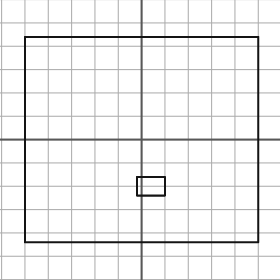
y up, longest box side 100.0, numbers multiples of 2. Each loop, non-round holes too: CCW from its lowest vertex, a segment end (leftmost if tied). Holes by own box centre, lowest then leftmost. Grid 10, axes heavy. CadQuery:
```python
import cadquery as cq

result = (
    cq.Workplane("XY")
    .moveTo(-50.0, -44.0)
    .lineTo(50.0, -44.0)
    .lineTo(50.0, 44.0)
    .lineTo(-50.0, 44.0)
    .close()
    .moveTo(-2.0, -24.0)
    .lineTo(10.0, -24.0)
    .lineTo(10.0, -16.0)
    .lineTo(-2.0, -16.0)
    .close()
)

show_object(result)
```